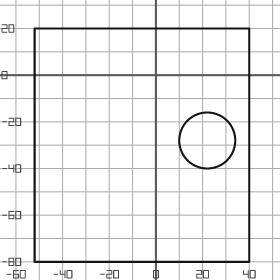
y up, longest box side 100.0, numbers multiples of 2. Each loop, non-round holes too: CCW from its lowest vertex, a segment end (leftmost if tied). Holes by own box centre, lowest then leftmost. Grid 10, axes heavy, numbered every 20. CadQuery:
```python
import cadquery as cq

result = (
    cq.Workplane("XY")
    .moveTo(-52.0, -80.0)
    .lineTo(40.0, -80.0)
    .lineTo(40.0, 20.0)
    .lineTo(-52.0, 20.0)
    .close()
    .moveTo(22.0, -28.0)
    .circle(12.0)
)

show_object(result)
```